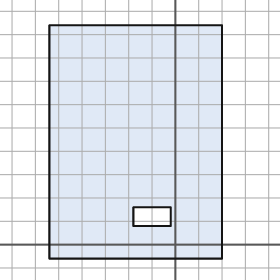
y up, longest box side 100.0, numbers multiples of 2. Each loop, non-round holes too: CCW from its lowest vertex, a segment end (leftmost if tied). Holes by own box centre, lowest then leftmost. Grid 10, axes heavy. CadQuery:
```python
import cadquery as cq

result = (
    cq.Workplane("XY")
    .moveTo(-54.0, -6.0)
    .lineTo(20.0, -6.0)
    .lineTo(20.0, 94.0)
    .lineTo(-54.0, 94.0)
    .close()
    .moveTo(-18.0, 8.0)
    .lineTo(-2.0, 8.0)
    .lineTo(-2.0, 16.0)
    .lineTo(-18.0, 16.0)
    .close()
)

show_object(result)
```